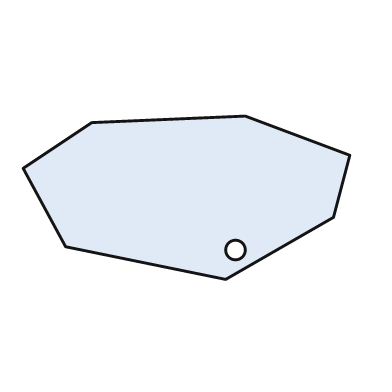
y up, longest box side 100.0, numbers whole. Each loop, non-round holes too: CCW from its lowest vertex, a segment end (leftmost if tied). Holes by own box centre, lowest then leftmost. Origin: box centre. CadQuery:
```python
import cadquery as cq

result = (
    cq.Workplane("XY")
    .moveTo(12.0, -25.0)
    .lineTo(45.0, -6.0)
    .lineTo(50.0, 13.0)
    .lineTo(18.0, 25.0)
    .lineTo(-29.0, 23.0)
    .lineTo(-50.0, 9.0)
    .lineTo(-37.0, -15.0)
    .close()
    .moveTo(15.0, -16.0)
    .circle(3.0)
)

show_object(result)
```